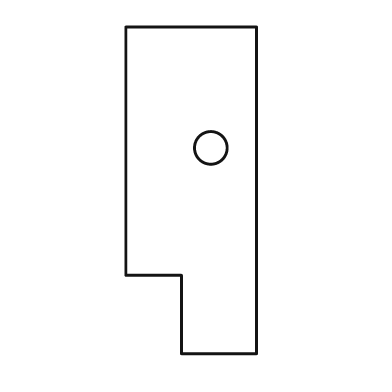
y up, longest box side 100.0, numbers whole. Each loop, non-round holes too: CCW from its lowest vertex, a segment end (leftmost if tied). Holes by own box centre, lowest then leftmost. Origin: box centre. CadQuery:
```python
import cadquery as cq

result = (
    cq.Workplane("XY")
    .moveTo(-3.0, -50.0)
    .lineTo(20.0, -50.0)
    .lineTo(20.0, 50.0)
    .lineTo(-20.0, 50.0)
    .lineTo(-20.0, -26.0)
    .lineTo(-3.0, -26.0)
    .close()
    .moveTo(6.0, 13.0)
    .circle(5.0)
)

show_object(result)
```